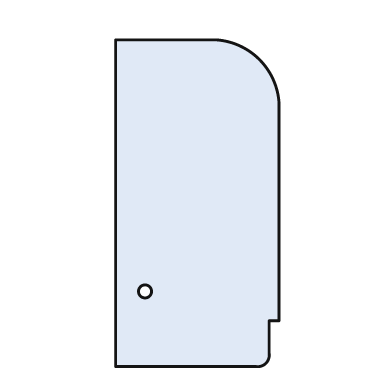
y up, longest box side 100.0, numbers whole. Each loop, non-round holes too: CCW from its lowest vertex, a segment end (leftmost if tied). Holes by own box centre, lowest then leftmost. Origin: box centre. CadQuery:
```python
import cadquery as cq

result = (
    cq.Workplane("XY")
    .moveTo(-25.0, -50.0)
    .lineTo(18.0, -50.0)
    .threePointArc((21.0, -49.0), (22.0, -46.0))
    .lineTo(22.0, -36.0)
    .lineTo(25.0, -36.0)
    .lineTo(25.0, 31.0)
    .threePointArc((19.0, 44.0), (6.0, 50.0))
    .lineTo(-25.0, 50.0)
    .close()
    .moveTo(-16.0, -27.0)
    .circle(2.0)
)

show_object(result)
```